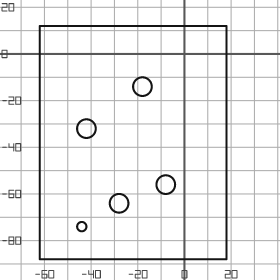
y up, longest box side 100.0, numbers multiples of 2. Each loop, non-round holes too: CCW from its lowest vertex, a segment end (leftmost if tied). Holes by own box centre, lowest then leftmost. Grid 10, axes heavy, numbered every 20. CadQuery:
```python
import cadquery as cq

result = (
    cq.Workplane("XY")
    .moveTo(-62.0, -88.0)
    .lineTo(18.0, -88.0)
    .lineTo(18.0, 12.0)
    .lineTo(-62.0, 12.0)
    .close()
    .moveTo(-44.0, -74.0)
    .circle(2.0)
    .moveTo(-28.0, -64.0)
    .circle(4.0)
    .moveTo(-8.0, -56.0)
    .circle(4.0)
    .moveTo(-42.0, -32.0)
    .circle(4.0)
    .moveTo(-18.0, -14.0)
    .circle(4.0)
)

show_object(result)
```